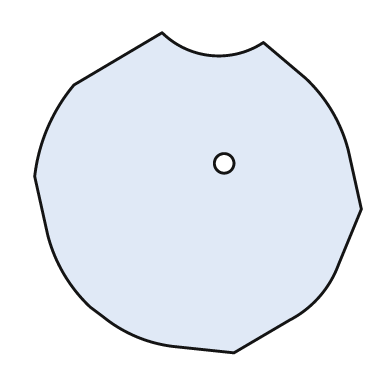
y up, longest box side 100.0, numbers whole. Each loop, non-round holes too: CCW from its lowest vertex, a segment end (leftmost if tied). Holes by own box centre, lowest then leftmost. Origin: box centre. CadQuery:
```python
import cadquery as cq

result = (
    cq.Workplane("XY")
    .moveTo(11.0, -49.0)
    .lineTo(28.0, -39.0)
    .threePointArc((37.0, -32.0), (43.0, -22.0))
    .lineTo(50.0, -5.0)
    .lineTo(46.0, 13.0)
    .threePointArc((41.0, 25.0), (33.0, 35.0))
    .lineTo(20.0, 46.0)
    .threePointArc((4.0, 42.0), (-11.0, 49.0))
    .lineTo(-38.0, 33.0)
    .threePointArc((-46.0, 20.0), (-50.0, 5.0))
    .lineTo(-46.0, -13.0)
    .threePointArc((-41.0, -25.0), (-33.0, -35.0))
    .lineTo(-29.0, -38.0)
    .threePointArc((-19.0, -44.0), (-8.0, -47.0))
    .close()
    .moveTo(8.0, 9.0)
    .circle(3.0)
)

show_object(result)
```